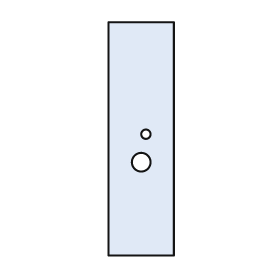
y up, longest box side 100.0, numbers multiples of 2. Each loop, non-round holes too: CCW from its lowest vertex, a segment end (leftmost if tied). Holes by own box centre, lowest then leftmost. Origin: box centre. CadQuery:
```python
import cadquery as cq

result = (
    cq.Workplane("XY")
    .moveTo(-14.0, -50.0)
    .lineTo(14.0, -50.0)
    .lineTo(14.0, 50.0)
    .lineTo(-14.0, 50.0)
    .close()
    .moveTo(0.0, -10.0)
    .circle(4.0)
    .moveTo(2.0, 2.0)
    .circle(2.0)
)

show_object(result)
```